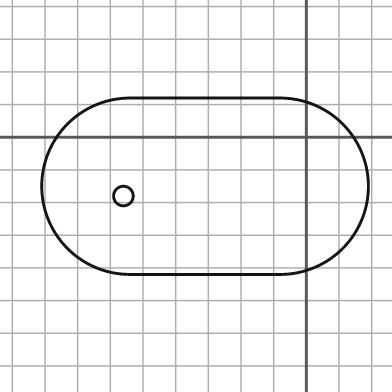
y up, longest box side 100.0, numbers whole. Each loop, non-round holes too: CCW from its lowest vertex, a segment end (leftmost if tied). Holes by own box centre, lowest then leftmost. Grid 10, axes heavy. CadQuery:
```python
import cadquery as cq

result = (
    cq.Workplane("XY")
    .moveTo(-54.0, -42.0)
    .lineTo(-8.0, -42.0)
    .threePointArc((19.0, -15.0), (-8.0, 12.0))
    .lineTo(-54.0, 12.0)
    .threePointArc((-81.0, -15.0), (-54.0, -42.0))
    .close()
    .moveTo(-56.0, -18.0)
    .circle(3.0)
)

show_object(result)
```